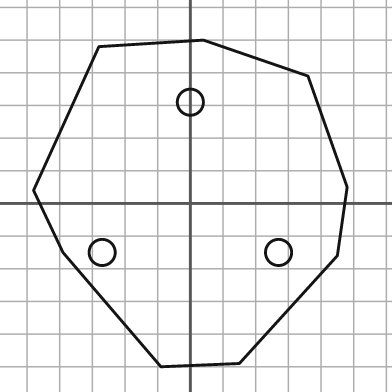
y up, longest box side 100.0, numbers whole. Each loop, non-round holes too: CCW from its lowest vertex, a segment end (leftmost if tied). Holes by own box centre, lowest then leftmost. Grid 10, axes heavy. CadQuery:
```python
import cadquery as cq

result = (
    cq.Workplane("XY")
    .moveTo(-9.0, -50.0)
    .lineTo(15.0, -49.0)
    .lineTo(45.0, -16.0)
    .lineTo(48.0, 5.0)
    .lineTo(36.0, 39.0)
    .lineTo(4.0, 50.0)
    .lineTo(-28.0, 48.0)
    .lineTo(-48.0, 4.0)
    .lineTo(-39.0, -15.0)
    .close()
    .moveTo(-27.0, -15.0)
    .circle(4.0)
    .moveTo(27.0, -15.0)
    .circle(4.0)
    .moveTo(0.0, 31.0)
    .circle(4.0)
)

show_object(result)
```